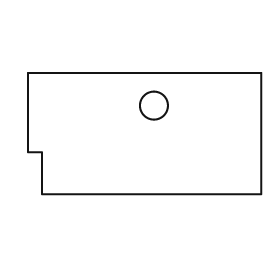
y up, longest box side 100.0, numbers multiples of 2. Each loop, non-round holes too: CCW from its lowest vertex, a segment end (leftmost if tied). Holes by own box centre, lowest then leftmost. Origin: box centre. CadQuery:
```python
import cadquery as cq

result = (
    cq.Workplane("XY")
    .moveTo(-44.0, -26.0)
    .lineTo(50.0, -26.0)
    .lineTo(50.0, 26.0)
    .lineTo(-50.0, 26.0)
    .lineTo(-50.0, -8.0)
    .lineTo(-44.0, -8.0)
    .close()
    .moveTo(4.0, 12.0)
    .circle(6.0)
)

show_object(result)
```